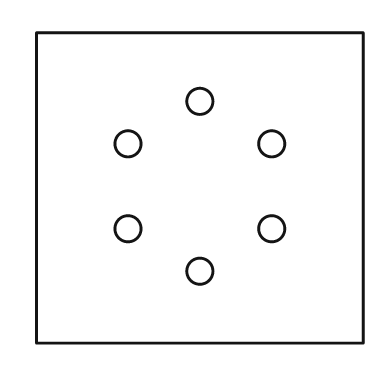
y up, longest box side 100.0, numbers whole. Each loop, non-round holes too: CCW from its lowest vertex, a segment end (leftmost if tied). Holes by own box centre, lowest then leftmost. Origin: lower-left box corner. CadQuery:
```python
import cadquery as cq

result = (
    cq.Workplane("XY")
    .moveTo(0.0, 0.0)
    .lineTo(100.0, 0.0)
    .lineTo(100.0, 95.0)
    .lineTo(0.0, 95.0)
    .close()
    .moveTo(50.0, 22.0)
    .circle(4.0)
    .moveTo(28.0, 35.0)
    .circle(4.0)
    .moveTo(72.0, 35.0)
    .circle(4.0)
    .moveTo(28.0, 61.0)
    .circle(4.0)
    .moveTo(72.0, 61.0)
    .circle(4.0)
    .moveTo(50.0, 74.0)
    .circle(4.0)
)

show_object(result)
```